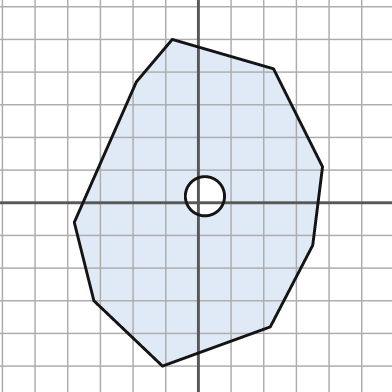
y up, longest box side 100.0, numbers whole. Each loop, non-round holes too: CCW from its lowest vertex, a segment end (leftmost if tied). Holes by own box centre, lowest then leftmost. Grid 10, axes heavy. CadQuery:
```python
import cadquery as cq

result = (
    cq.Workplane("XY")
    .moveTo(-11.0, -50.0)
    .lineTo(22.0, -38.0)
    .lineTo(35.0, -13.0)
    .lineTo(38.0, 11.0)
    .lineTo(23.0, 41.0)
    .lineTo(-8.0, 50.0)
    .lineTo(-19.0, 37.0)
    .lineTo(-38.0, -6.0)
    .lineTo(-32.0, -30.0)
    .close()
    .moveTo(2.0, 2.0)
    .circle(6.0)
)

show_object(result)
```